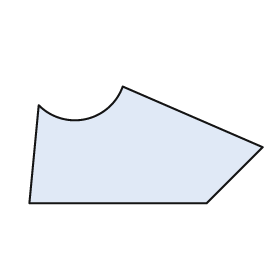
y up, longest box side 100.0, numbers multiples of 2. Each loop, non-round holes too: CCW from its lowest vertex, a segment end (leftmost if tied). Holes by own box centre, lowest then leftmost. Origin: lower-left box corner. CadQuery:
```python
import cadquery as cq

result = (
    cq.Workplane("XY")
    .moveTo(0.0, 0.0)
    .lineTo(76.0, 0.0)
    .lineTo(100.0, 24.0)
    .lineTo(40.0, 50.0)
    .threePointArc((24.0, 36.0), (4.0, 42.0))
    .close()
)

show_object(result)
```